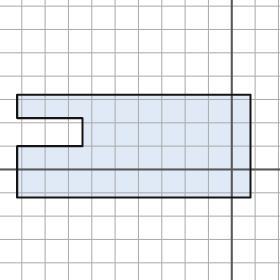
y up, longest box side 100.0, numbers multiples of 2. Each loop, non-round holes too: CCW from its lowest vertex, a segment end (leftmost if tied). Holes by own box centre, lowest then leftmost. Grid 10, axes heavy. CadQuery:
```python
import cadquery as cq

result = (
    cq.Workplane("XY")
    .moveTo(-92.0, -12.0)
    .lineTo(8.0, -12.0)
    .lineTo(8.0, 32.0)
    .lineTo(-92.0, 32.0)
    .lineTo(-92.0, 22.0)
    .lineTo(-64.0, 22.0)
    .lineTo(-64.0, 10.0)
    .lineTo(-92.0, 10.0)
    .close()
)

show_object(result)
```